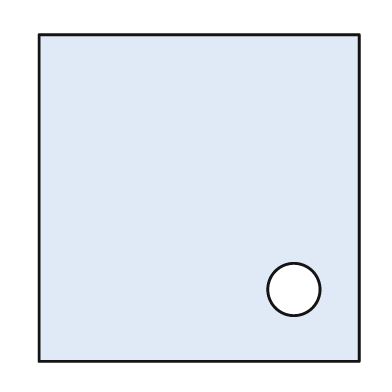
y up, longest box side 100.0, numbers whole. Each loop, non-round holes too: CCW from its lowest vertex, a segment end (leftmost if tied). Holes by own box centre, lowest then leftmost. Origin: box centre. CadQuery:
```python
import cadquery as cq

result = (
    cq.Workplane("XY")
    .moveTo(-49.0, -50.0)
    .lineTo(49.0, -50.0)
    .lineTo(49.0, 50.0)
    .lineTo(-49.0, 50.0)
    .close()
    .moveTo(29.0, -28.0)
    .circle(8.0)
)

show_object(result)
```